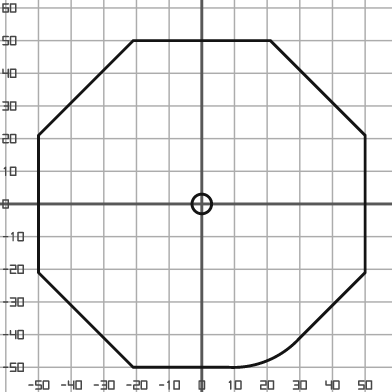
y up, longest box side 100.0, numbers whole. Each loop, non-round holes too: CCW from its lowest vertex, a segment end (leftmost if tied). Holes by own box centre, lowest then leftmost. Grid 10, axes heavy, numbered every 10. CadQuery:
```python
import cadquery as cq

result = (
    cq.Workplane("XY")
    .moveTo(-21.0, -50.0)
    .lineTo(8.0, -50.0)
    .threePointArc((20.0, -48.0), (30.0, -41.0))
    .lineTo(50.0, -21.0)
    .lineTo(50.0, 21.0)
    .lineTo(21.0, 50.0)
    .lineTo(-21.0, 50.0)
    .lineTo(-50.0, 21.0)
    .lineTo(-50.0, -21.0)
    .close()
    .moveTo(0.0, 0.0)
    .circle(3.0)
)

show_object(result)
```